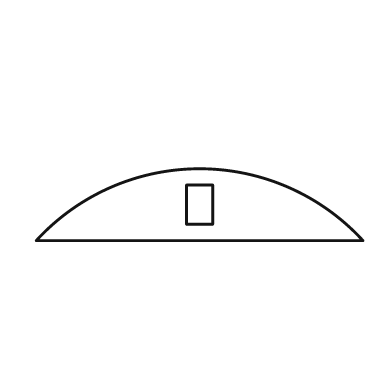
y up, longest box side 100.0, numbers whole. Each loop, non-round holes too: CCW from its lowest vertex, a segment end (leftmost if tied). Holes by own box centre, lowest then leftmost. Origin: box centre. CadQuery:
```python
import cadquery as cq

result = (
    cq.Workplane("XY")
    .moveTo(-50.0, -11.0)
    .lineTo(50.0, -11.0)
    .threePointArc((0.0, 11.0), (-50.0, -11.0))
    .close()
    .moveTo(-4.0, -6.0)
    .lineTo(4.0, -6.0)
    .lineTo(4.0, 6.0)
    .lineTo(-4.0, 6.0)
    .close()
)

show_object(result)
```